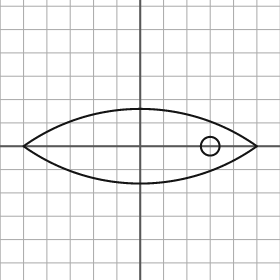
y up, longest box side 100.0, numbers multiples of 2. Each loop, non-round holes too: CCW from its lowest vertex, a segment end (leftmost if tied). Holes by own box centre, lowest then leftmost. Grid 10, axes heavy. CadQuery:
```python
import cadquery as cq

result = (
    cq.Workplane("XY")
    .moveTo(-50.0, 0.0)
    .threePointArc((0.0, -16.0), (50.0, 0.0))
    .threePointArc((0.0, 16.0), (-50.0, 0.0))
    .close()
    .moveTo(30.0, 0.0)
    .circle(4.0)
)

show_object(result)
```